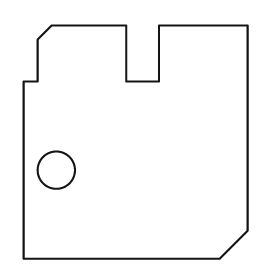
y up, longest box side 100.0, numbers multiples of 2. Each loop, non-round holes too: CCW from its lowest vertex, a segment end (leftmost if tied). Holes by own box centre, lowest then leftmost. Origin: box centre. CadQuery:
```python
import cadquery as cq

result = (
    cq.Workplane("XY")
    .moveTo(-48.0, -50.0)
    .lineTo(36.0, -50.0)
    .lineTo(48.0, -38.0)
    .lineTo(48.0, 50.0)
    .lineTo(10.0, 50.0)
    .lineTo(10.0, 26.0)
    .lineTo(-4.0, 26.0)
    .lineTo(-4.0, 50.0)
    .lineTo(-36.0, 50.0)
    .lineTo(-42.0, 44.0)
    .lineTo(-42.0, 26.0)
    .lineTo(-48.0, 26.0)
    .close()
    .moveTo(-34.0, -12.0)
    .circle(8.0)
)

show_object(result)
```